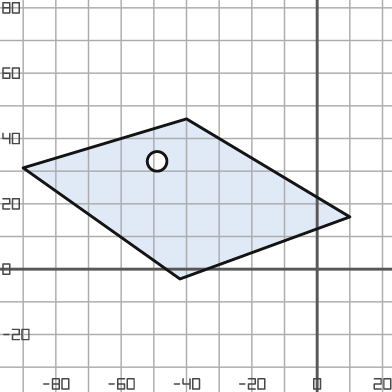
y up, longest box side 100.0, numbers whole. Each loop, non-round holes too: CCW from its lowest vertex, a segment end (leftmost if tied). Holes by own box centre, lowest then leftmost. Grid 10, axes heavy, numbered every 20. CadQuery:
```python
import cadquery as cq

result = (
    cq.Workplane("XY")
    .moveTo(-42.0, -3.0)
    .lineTo(10.0, 16.0)
    .lineTo(-40.0, 46.0)
    .lineTo(-90.0, 31.0)
    .close()
    .moveTo(-49.0, 33.0)
    .circle(3.0)
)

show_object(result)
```